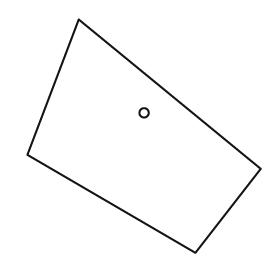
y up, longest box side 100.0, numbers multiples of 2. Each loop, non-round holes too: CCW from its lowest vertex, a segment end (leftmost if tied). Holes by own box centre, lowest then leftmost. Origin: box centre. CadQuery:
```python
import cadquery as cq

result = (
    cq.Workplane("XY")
    .moveTo(22.0, -50.0)
    .lineTo(50.0, -14.0)
    .lineTo(-28.0, 50.0)
    .lineTo(-50.0, -8.0)
    .close()
    .moveTo(0.0, 10.0)
    .circle(2.0)
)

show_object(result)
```